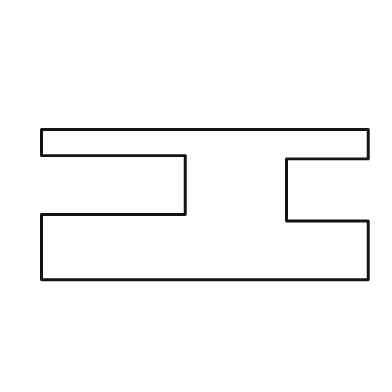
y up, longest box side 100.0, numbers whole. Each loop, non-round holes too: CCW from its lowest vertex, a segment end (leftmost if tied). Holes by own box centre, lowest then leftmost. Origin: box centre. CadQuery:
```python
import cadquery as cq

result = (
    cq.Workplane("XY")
    .moveTo(-50.0, -23.0)
    .lineTo(50.0, -23.0)
    .lineTo(50.0, -5.0)
    .lineTo(25.0, -5.0)
    .lineTo(25.0, 14.0)
    .lineTo(50.0, 14.0)
    .lineTo(50.0, 23.0)
    .lineTo(-50.0, 23.0)
    .lineTo(-50.0, 15.0)
    .lineTo(-6.0, 15.0)
    .lineTo(-6.0, -3.0)
    .lineTo(-50.0, -3.0)
    .close()
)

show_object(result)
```